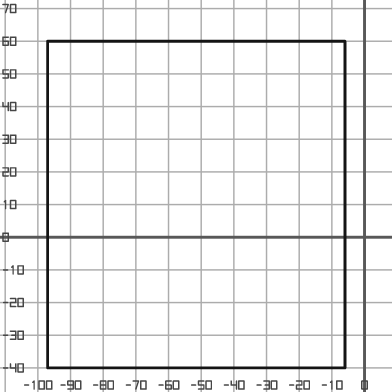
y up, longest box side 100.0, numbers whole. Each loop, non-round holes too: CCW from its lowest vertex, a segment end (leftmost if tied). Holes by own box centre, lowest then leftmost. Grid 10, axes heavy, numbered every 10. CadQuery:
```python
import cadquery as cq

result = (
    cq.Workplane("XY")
    .moveTo(-97.0, -40.0)
    .lineTo(-6.0, -40.0)
    .lineTo(-6.0, 60.0)
    .lineTo(-97.0, 60.0)
    .close()
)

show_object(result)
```